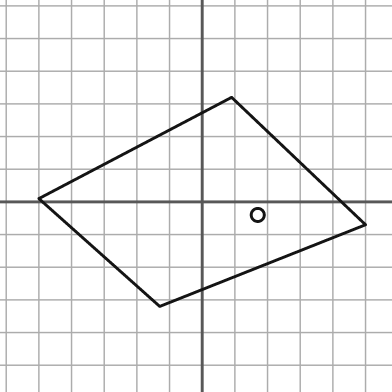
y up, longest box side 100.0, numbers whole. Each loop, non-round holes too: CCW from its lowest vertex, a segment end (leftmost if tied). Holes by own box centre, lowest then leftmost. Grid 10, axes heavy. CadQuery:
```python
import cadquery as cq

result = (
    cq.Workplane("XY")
    .moveTo(-13.0, -32.0)
    .lineTo(50.0, -7.0)
    .lineTo(9.0, 32.0)
    .lineTo(-50.0, 1.0)
    .close()
    .moveTo(17.0, -4.0)
    .circle(2.0)
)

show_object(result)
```